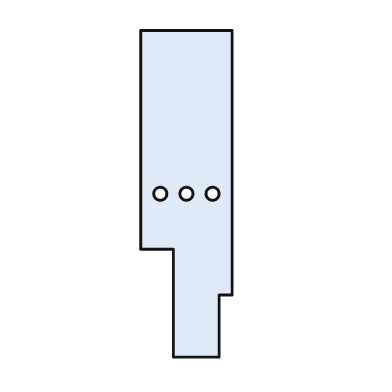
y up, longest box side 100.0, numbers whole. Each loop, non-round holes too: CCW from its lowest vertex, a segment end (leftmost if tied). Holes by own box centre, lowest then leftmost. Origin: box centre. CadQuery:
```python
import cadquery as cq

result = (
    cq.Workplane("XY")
    .moveTo(-4.0, -50.0)
    .lineTo(10.0, -50.0)
    .lineTo(10.0, -31.0)
    .lineTo(14.0, -31.0)
    .lineTo(14.0, 50.0)
    .lineTo(-14.0, 50.0)
    .lineTo(-14.0, -17.0)
    .lineTo(-4.0, -17.0)
    .close()
    .moveTo(-8.0, 0.0)
    .circle(2.0)
    .moveTo(0.0, 0.0)
    .circle(2.0)
    .moveTo(8.0, 0.0)
    .circle(2.0)
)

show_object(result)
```